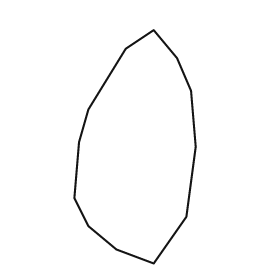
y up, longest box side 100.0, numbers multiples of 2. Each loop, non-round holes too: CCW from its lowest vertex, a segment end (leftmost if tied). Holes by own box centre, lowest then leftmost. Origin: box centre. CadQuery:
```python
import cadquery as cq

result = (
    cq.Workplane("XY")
    .moveTo(8.0, -50.0)
    .lineTo(22.0, -30.0)
    .lineTo(26.0, 0.0)
    .lineTo(24.0, 24.0)
    .lineTo(18.0, 38.0)
    .lineTo(8.0, 50.0)
    .lineTo(-4.0, 42.0)
    .lineTo(-20.0, 16.0)
    .lineTo(-24.0, 2.0)
    .lineTo(-26.0, -22.0)
    .lineTo(-20.0, -34.0)
    .lineTo(-8.0, -44.0)
    .close()
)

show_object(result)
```